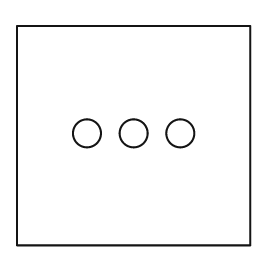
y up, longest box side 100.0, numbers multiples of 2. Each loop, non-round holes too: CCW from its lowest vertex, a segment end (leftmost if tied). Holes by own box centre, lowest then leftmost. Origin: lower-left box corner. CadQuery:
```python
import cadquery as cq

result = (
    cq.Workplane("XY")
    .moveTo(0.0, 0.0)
    .lineTo(100.0, 0.0)
    .lineTo(100.0, 94.0)
    .lineTo(0.0, 94.0)
    .close()
    .moveTo(30.0, 48.0)
    .circle(6.0)
    .moveTo(50.0, 48.0)
    .circle(6.0)
    .moveTo(70.0, 48.0)
    .circle(6.0)
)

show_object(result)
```